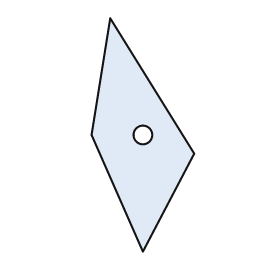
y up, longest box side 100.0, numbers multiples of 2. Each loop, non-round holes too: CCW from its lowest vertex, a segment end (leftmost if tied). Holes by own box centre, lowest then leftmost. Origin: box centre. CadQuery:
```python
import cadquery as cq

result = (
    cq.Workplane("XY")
    .moveTo(0.0, -50.0)
    .lineTo(22.0, -8.0)
    .lineTo(-14.0, 50.0)
    .lineTo(-22.0, 0.0)
    .close()
    .moveTo(0.0, 0.0)
    .circle(4.0)
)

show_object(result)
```